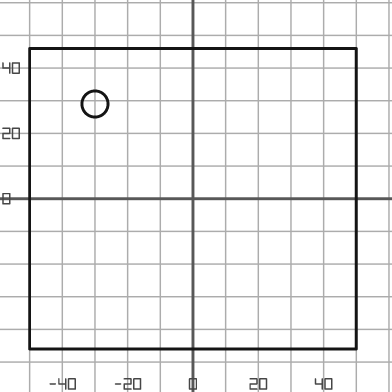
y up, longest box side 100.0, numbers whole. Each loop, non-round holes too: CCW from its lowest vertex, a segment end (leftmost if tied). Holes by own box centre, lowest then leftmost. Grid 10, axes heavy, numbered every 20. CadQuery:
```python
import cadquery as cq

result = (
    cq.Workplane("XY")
    .moveTo(-50.0, -46.0)
    .lineTo(50.0, -46.0)
    .lineTo(50.0, 46.0)
    .lineTo(-50.0, 46.0)
    .close()
    .moveTo(-30.0, 29.0)
    .circle(4.0)
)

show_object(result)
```